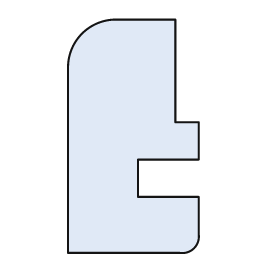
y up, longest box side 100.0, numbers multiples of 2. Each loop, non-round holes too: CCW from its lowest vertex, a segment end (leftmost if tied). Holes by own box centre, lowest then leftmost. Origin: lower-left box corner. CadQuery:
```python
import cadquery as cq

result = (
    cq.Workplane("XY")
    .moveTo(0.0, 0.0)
    .lineTo(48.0, 0.0)
    .threePointArc((54.0, 2.0), (56.0, 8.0))
    .lineTo(56.0, 24.0)
    .lineTo(30.0, 24.0)
    .lineTo(30.0, 40.0)
    .lineTo(56.0, 40.0)
    .lineTo(56.0, 56.0)
    .lineTo(46.0, 56.0)
    .lineTo(46.0, 100.0)
    .lineTo(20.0, 100.0)
    .threePointArc((6.0, 94.0), (0.0, 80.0))
    .close()
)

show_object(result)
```